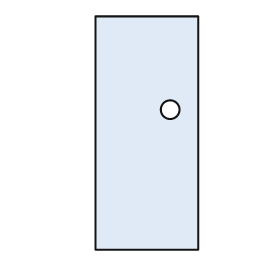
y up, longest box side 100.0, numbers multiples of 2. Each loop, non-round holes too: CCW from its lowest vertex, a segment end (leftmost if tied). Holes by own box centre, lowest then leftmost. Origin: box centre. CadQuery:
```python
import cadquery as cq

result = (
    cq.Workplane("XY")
    .moveTo(-22.0, -50.0)
    .lineTo(22.0, -50.0)
    .lineTo(22.0, 50.0)
    .lineTo(-22.0, 50.0)
    .close()
    .moveTo(10.0, 10.0)
    .circle(4.0)
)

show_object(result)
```